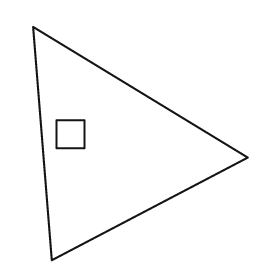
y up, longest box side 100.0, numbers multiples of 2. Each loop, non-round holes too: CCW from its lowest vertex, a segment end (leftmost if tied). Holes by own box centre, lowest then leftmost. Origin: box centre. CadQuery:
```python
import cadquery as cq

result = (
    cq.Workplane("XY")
    .moveTo(-38.0, -50.0)
    .lineTo(46.0, -6.0)
    .lineTo(-46.0, 50.0)
    .close()
    .moveTo(-36.0, -2.0)
    .lineTo(-24.0, -2.0)
    .lineTo(-24.0, 10.0)
    .lineTo(-36.0, 10.0)
    .close()
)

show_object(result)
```